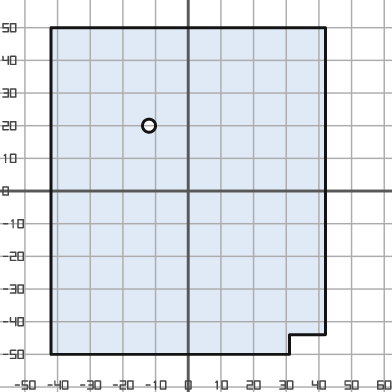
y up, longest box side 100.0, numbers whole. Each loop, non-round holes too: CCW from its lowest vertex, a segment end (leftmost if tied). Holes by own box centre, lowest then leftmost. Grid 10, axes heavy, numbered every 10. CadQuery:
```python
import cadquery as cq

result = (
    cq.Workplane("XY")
    .moveTo(-42.0, -50.0)
    .lineTo(31.0, -50.0)
    .lineTo(31.0, -44.0)
    .lineTo(42.0, -44.0)
    .lineTo(42.0, 50.0)
    .lineTo(-42.0, 50.0)
    .close()
    .moveTo(-12.0, 20.0)
    .circle(2.0)
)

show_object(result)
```